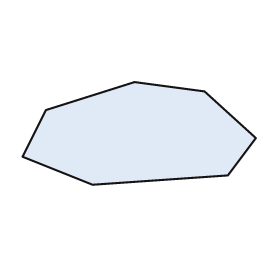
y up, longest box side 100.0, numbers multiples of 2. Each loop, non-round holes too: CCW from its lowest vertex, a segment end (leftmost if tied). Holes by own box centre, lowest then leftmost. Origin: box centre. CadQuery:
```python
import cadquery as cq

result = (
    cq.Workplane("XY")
    .moveTo(-20.0, -22.0)
    .lineTo(38.0, -18.0)
    .lineTo(50.0, -2.0)
    .lineTo(28.0, 18.0)
    .lineTo(-2.0, 22.0)
    .lineTo(-40.0, 10.0)
    .lineTo(-50.0, -10.0)
    .close()
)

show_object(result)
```